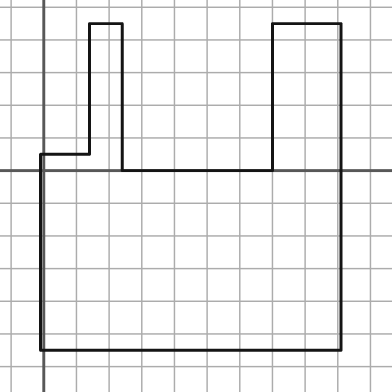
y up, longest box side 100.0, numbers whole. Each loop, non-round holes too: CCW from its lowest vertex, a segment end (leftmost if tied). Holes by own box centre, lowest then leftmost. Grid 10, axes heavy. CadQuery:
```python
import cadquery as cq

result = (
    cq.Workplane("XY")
    .moveTo(-1.0, -55.0)
    .lineTo(91.0, -55.0)
    .lineTo(91.0, 45.0)
    .lineTo(70.0, 45.0)
    .lineTo(70.0, 0.0)
    .lineTo(24.0, 0.0)
    .lineTo(24.0, 45.0)
    .lineTo(14.0, 45.0)
    .lineTo(14.0, 5.0)
    .lineTo(-1.0, 5.0)
    .close()
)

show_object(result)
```